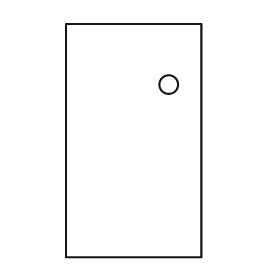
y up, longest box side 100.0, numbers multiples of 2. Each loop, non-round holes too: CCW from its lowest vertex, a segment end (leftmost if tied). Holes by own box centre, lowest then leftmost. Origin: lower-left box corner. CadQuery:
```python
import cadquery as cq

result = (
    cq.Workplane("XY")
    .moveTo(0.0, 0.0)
    .lineTo(58.0, 0.0)
    .lineTo(58.0, 100.0)
    .lineTo(0.0, 100.0)
    .close()
    .moveTo(44.0, 74.0)
    .circle(4.0)
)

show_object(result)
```